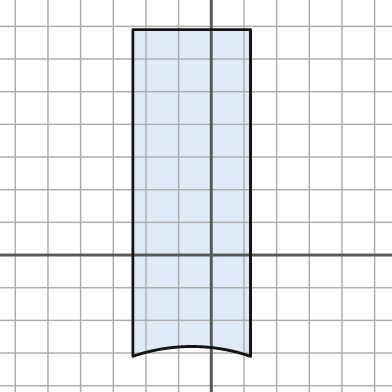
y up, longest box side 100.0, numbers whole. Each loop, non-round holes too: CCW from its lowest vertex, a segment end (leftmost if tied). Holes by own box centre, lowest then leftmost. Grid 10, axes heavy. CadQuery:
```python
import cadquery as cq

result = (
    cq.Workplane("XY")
    .moveTo(-24.0, -31.0)
    .threePointArc((-6.0, -28.0), (12.0, -31.0))
    .lineTo(12.0, 69.0)
    .lineTo(-24.0, 69.0)
    .close()
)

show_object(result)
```